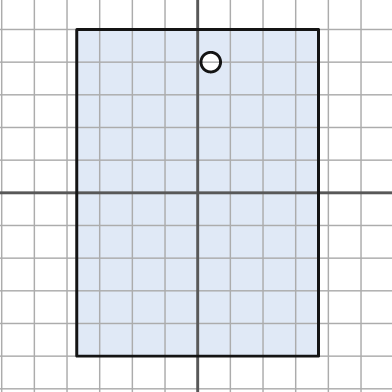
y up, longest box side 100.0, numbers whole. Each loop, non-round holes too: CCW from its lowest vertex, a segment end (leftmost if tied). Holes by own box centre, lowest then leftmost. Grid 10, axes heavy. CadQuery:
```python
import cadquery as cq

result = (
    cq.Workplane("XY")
    .moveTo(-37.0, -50.0)
    .lineTo(37.0, -50.0)
    .lineTo(37.0, 50.0)
    .lineTo(-37.0, 50.0)
    .close()
    .moveTo(4.0, 40.0)
    .circle(3.0)
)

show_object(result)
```